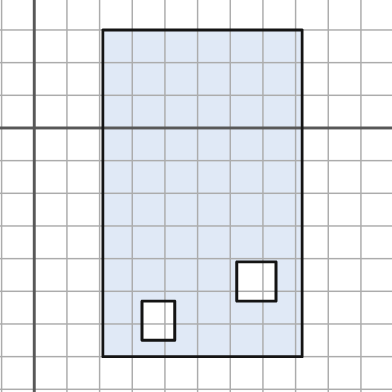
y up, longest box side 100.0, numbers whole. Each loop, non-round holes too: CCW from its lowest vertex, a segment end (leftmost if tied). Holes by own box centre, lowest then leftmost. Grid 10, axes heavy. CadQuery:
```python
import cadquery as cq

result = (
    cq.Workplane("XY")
    .moveTo(21.0, -70.0)
    .lineTo(82.0, -70.0)
    .lineTo(82.0, 30.0)
    .lineTo(21.0, 30.0)
    .close()
    .moveTo(33.0, -65.0)
    .lineTo(43.0, -65.0)
    .lineTo(43.0, -53.0)
    .lineTo(33.0, -53.0)
    .close()
    .moveTo(62.0, -53.0)
    .lineTo(74.0, -53.0)
    .lineTo(74.0, -41.0)
    .lineTo(62.0, -41.0)
    .close()
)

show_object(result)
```